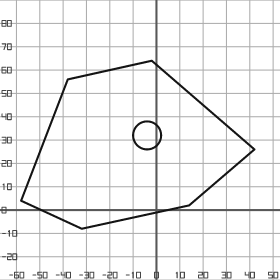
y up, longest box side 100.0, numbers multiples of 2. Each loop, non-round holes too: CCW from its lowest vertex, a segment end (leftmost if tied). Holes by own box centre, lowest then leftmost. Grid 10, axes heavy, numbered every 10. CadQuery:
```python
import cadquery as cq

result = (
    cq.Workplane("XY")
    .moveTo(-32.0, -8.0)
    .lineTo(14.0, 2.0)
    .lineTo(42.0, 26.0)
    .lineTo(-2.0, 64.0)
    .lineTo(-38.0, 56.0)
    .lineTo(-58.0, 4.0)
    .close()
    .moveTo(-4.0, 32.0)
    .circle(6.0)
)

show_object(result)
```